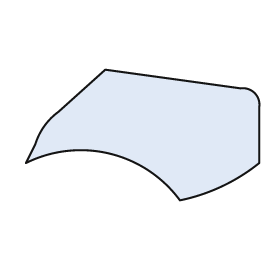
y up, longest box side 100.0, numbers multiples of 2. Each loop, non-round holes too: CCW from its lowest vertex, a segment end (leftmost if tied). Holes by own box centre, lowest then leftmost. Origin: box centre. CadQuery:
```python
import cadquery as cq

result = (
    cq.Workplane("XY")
    .moveTo(16.0, -28.0)
    .threePointArc((34.0, -22.0), (50.0, -12.0))
    .lineTo(50.0, 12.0)
    .threePointArc((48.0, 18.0), (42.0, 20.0))
    .lineTo(-16.0, 28.0)
    .lineTo(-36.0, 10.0)
    .threePointArc((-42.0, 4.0), (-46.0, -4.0))
    .lineTo(-50.0, -12.0)
    .threePointArc((-14.0, -8.0), (16.0, -28.0))
    .close()
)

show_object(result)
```